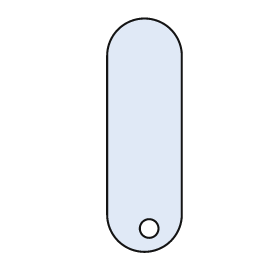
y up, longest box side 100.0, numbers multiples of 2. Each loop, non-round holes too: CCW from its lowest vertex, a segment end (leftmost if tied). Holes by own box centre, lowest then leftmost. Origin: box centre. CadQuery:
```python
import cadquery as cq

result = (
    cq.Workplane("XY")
    .moveTo(-16.0, -34.0)
    .threePointArc((0.0, -50.0), (16.0, -34.0))
    .lineTo(16.0, 34.0)
    .threePointArc((0.0, 50.0), (-16.0, 34.0))
    .close()
    .moveTo(2.0, -40.0)
    .circle(4.0)
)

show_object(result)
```